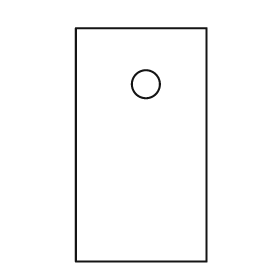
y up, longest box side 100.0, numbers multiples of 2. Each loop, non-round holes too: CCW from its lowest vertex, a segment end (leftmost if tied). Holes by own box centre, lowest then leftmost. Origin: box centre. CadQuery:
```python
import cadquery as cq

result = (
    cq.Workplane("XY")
    .moveTo(-28.0, -50.0)
    .lineTo(28.0, -50.0)
    .lineTo(28.0, 50.0)
    .lineTo(-28.0, 50.0)
    .close()
    .moveTo(2.0, 26.0)
    .circle(6.0)
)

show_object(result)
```